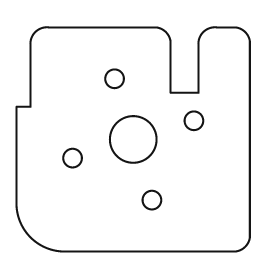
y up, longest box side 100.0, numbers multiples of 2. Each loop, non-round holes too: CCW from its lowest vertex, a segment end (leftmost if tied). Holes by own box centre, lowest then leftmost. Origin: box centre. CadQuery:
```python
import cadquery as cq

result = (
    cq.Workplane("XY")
    .moveTo(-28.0, -48.0)
    .lineTo(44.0, -48.0)
    .threePointArc((48.0, -46.0), (50.0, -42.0))
    .lineTo(50.0, 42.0)
    .threePointArc((48.0, 46.0), (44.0, 48.0))
    .lineTo(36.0, 48.0)
    .threePointArc((30.0, 46.0), (28.0, 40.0))
    .lineTo(28.0, 20.0)
    .lineTo(16.0, 20.0)
    .lineTo(16.0, 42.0)
    .threePointArc((14.0, 46.0), (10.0, 48.0))
    .lineTo(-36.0, 48.0)
    .threePointArc((-42.0, 46.0), (-44.0, 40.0))
    .lineTo(-44.0, 14.0)
    .lineTo(-50.0, 14.0)
    .lineTo(-50.0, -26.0)
    .threePointArc((-44.0, -42.0), (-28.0, -48.0))
    .close()
    .moveTo(8.0, -26.0)
    .circle(4.0)
    .moveTo(-26.0, -8.0)
    .circle(4.0)
    .moveTo(0.0, 0.0)
    .circle(10.0)
    .moveTo(26.0, 8.0)
    .circle(4.0)
    .moveTo(-8.0, 26.0)
    .circle(4.0)
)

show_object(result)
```